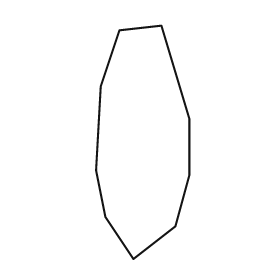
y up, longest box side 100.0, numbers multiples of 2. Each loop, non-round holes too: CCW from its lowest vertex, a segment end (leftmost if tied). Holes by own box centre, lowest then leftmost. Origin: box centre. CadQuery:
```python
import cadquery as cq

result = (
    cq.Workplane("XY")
    .moveTo(-4.0, -50.0)
    .lineTo(14.0, -36.0)
    .lineTo(20.0, -14.0)
    .lineTo(20.0, 10.0)
    .lineTo(8.0, 50.0)
    .lineTo(-10.0, 48.0)
    .lineTo(-18.0, 24.0)
    .lineTo(-20.0, -12.0)
    .lineTo(-16.0, -32.0)
    .close()
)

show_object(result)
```